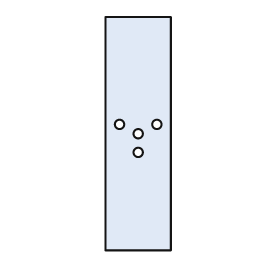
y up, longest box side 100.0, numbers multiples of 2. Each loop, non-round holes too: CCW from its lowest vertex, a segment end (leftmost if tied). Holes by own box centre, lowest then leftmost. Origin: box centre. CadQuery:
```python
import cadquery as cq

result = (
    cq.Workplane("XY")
    .moveTo(-14.0, -50.0)
    .lineTo(14.0, -50.0)
    .lineTo(14.0, 50.0)
    .lineTo(-14.0, 50.0)
    .close()
    .moveTo(0.0, -8.0)
    .circle(2.0)
    .moveTo(0.0, 0.0)
    .circle(2.0)
    .moveTo(-8.0, 4.0)
    .circle(2.0)
    .moveTo(8.0, 4.0)
    .circle(2.0)
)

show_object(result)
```